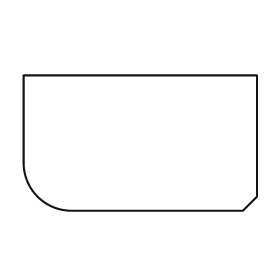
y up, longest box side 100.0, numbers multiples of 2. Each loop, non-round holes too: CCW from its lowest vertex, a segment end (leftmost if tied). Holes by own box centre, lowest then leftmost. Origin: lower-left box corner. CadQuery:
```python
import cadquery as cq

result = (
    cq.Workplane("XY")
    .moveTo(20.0, 0.0)
    .lineTo(94.0, 0.0)
    .lineTo(100.0, 6.0)
    .lineTo(100.0, 58.0)
    .lineTo(0.0, 58.0)
    .lineTo(0.0, 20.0)
    .threePointArc((6.0, 6.0), (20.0, 0.0))
    .close()
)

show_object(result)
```